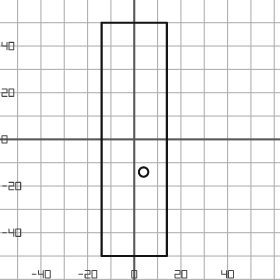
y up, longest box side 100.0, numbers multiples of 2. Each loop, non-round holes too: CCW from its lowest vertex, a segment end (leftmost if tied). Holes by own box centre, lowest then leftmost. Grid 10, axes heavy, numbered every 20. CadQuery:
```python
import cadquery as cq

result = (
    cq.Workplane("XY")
    .moveTo(-14.0, -50.0)
    .lineTo(14.0, -50.0)
    .lineTo(14.0, 50.0)
    .lineTo(-14.0, 50.0)
    .close()
    .moveTo(4.0, -14.0)
    .circle(2.0)
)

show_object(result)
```